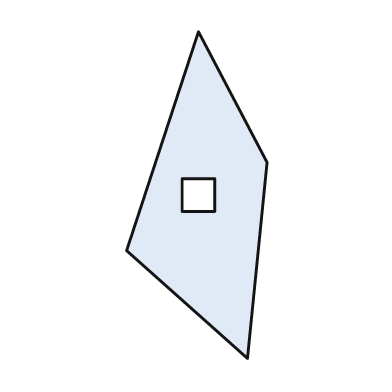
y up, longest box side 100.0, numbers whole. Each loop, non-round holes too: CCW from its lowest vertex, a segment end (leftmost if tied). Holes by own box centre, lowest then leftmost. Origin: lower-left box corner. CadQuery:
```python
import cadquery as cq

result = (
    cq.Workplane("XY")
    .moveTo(37.0, 0.0)
    .lineTo(43.0, 60.0)
    .lineTo(22.0, 100.0)
    .lineTo(0.0, 33.0)
    .close()
    .moveTo(17.0, 45.0)
    .lineTo(27.0, 45.0)
    .lineTo(27.0, 55.0)
    .lineTo(17.0, 55.0)
    .close()
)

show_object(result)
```